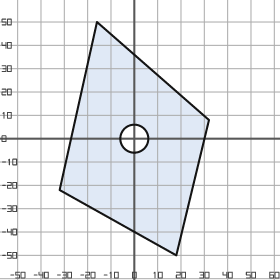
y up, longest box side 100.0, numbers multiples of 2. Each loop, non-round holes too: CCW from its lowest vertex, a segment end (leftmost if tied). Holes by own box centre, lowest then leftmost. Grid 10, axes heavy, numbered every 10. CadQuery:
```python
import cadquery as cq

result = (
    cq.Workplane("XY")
    .moveTo(18.0, -50.0)
    .lineTo(32.0, 8.0)
    .lineTo(-16.0, 50.0)
    .lineTo(-32.0, -22.0)
    .close()
    .moveTo(0.0, 0.0)
    .circle(6.0)
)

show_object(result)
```